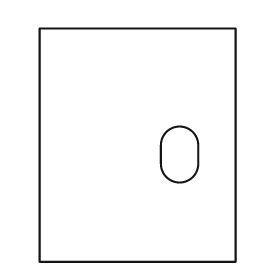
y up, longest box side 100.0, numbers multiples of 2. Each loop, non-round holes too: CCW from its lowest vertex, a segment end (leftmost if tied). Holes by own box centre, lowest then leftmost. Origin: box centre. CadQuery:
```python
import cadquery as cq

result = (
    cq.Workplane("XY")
    .moveTo(-42.0, -50.0)
    .lineTo(42.0, -50.0)
    .lineTo(42.0, 50.0)
    .lineTo(-42.0, 50.0)
    .close()
    .moveTo(10.0, -8.0)
    .threePointArc((18.0, -16.0), (26.0, -8.0))
    .lineTo(26.0, 0.0)
    .threePointArc((18.0, 8.0), (10.0, 0.0))
    .close()
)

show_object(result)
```